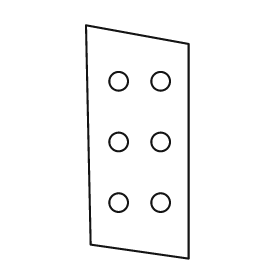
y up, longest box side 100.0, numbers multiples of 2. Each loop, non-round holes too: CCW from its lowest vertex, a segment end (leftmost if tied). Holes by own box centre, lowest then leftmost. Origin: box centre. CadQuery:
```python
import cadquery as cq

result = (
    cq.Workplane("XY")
    .moveTo(22.0, -50.0)
    .lineTo(22.0, 42.0)
    .lineTo(-22.0, 50.0)
    .lineTo(-20.0, -44.0)
    .close()
    .moveTo(-8.0, -26.0)
    .circle(4.0)
    .moveTo(10.0, -26.0)
    .circle(4.0)
    .moveTo(-8.0, 0.0)
    .circle(4.0)
    .moveTo(10.0, 0.0)
    .circle(4.0)
    .moveTo(-8.0, 26.0)
    .circle(4.0)
    .moveTo(10.0, 26.0)
    .circle(4.0)
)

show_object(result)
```